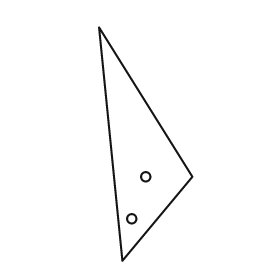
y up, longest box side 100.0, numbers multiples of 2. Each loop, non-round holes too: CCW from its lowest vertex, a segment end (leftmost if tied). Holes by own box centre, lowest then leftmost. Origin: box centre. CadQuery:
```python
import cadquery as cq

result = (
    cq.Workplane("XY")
    .moveTo(-10.0, -50.0)
    .lineTo(20.0, -14.0)
    .lineTo(-20.0, 50.0)
    .close()
    .moveTo(-6.0, -32.0)
    .circle(2.0)
    .moveTo(0.0, -14.0)
    .circle(2.0)
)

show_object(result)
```